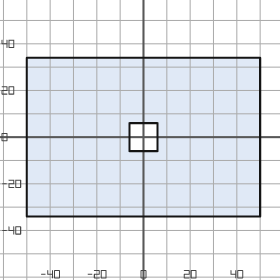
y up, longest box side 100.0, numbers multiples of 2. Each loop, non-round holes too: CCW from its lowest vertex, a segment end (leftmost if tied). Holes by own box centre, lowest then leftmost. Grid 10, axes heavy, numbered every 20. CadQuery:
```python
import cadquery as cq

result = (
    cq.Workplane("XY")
    .moveTo(-50.0, -34.0)
    .lineTo(50.0, -34.0)
    .lineTo(50.0, 34.0)
    .lineTo(-50.0, 34.0)
    .close()
    .moveTo(-6.0, -6.0)
    .lineTo(6.0, -6.0)
    .lineTo(6.0, 6.0)
    .lineTo(-6.0, 6.0)
    .close()
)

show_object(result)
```